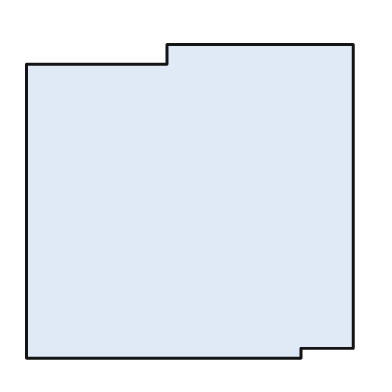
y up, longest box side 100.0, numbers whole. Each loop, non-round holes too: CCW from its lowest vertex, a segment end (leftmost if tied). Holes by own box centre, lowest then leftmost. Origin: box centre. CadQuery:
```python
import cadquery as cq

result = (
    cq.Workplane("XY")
    .moveTo(-50.0, -48.0)
    .lineTo(34.0, -48.0)
    .lineTo(34.0, -45.0)
    .lineTo(50.0, -45.0)
    .lineTo(50.0, 48.0)
    .lineTo(-7.0, 48.0)
    .lineTo(-7.0, 42.0)
    .lineTo(-50.0, 42.0)
    .close()
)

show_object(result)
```